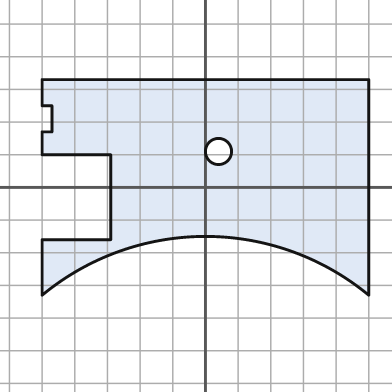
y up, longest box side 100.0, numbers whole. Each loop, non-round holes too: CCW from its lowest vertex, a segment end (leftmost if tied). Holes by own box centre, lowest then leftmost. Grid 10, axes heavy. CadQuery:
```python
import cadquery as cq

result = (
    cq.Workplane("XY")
    .moveTo(-50.0, -33.0)
    .threePointArc((0.0, -15.0), (50.0, -33.0))
    .lineTo(50.0, 33.0)
    .lineTo(-50.0, 33.0)
    .lineTo(-50.0, 25.0)
    .lineTo(-47.0, 25.0)
    .lineTo(-47.0, 17.0)
    .lineTo(-50.0, 17.0)
    .lineTo(-50.0, 10.0)
    .lineTo(-29.0, 10.0)
    .lineTo(-29.0, -16.0)
    .lineTo(-50.0, -16.0)
    .close()
    .moveTo(4.0, 11.0)
    .circle(4.0)
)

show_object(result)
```